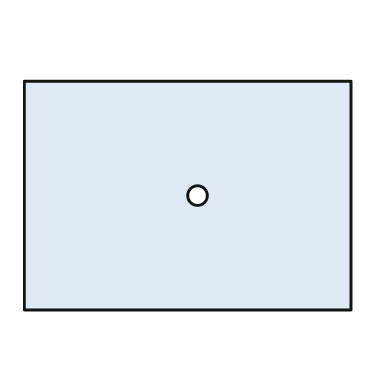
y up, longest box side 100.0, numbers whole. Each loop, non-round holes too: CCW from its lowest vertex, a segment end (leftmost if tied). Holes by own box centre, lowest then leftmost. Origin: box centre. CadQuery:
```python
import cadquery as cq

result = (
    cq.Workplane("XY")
    .moveTo(-50.0, -35.0)
    .lineTo(50.0, -35.0)
    .lineTo(50.0, 35.0)
    .lineTo(-50.0, 35.0)
    .close()
    .moveTo(3.0, 0.0)
    .circle(3.0)
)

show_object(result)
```